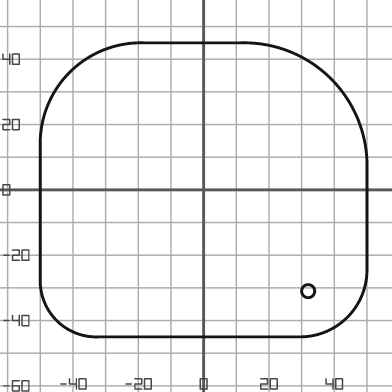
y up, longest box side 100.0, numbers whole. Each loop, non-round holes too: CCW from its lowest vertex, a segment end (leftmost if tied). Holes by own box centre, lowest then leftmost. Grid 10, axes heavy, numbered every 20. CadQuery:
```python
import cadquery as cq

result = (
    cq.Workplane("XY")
    .moveTo(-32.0, -45.0)
    .lineTo(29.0, -45.0)
    .threePointArc((44.0, -39.0), (50.0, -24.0))
    .lineTo(50.0, 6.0)
    .threePointArc((39.0, 34.0), (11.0, 45.0))
    .lineTo(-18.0, 45.0)
    .threePointArc((-41.0, 36.0), (-50.0, 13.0))
    .lineTo(-50.0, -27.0)
    .threePointArc((-45.0, -40.0), (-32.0, -45.0))
    .close()
    .moveTo(32.0, -31.0)
    .circle(2.0)
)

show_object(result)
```